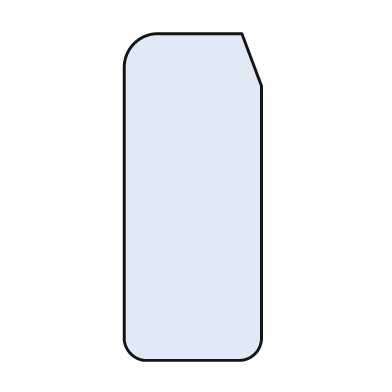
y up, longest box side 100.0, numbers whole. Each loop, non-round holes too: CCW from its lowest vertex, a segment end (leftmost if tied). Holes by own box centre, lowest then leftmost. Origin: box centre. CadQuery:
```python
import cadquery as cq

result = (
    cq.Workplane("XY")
    .moveTo(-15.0, -50.0)
    .lineTo(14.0, -50.0)
    .threePointArc((19.0, -48.0), (21.0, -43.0))
    .lineTo(21.0, 34.0)
    .lineTo(15.0, 50.0)
    .lineTo(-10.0, 50.0)
    .threePointArc((-18.0, 47.0), (-21.0, 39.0))
    .lineTo(-21.0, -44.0)
    .threePointArc((-19.0, -48.0), (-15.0, -50.0))
    .close()
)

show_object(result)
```